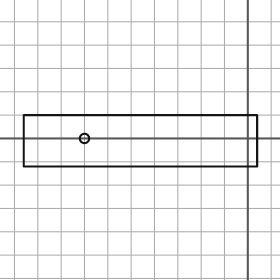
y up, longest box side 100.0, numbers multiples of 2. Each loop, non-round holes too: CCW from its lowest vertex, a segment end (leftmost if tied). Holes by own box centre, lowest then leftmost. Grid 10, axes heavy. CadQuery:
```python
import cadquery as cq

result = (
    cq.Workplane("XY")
    .moveTo(-96.0, -12.0)
    .lineTo(4.0, -12.0)
    .lineTo(4.0, 10.0)
    .lineTo(-96.0, 10.0)
    .close()
    .moveTo(-70.0, 0.0)
    .circle(2.0)
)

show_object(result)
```